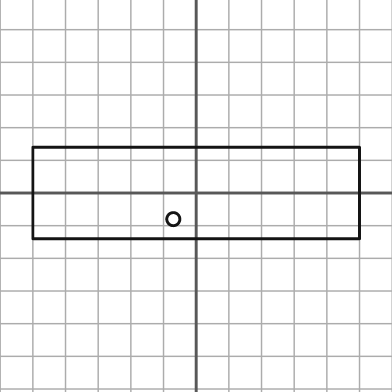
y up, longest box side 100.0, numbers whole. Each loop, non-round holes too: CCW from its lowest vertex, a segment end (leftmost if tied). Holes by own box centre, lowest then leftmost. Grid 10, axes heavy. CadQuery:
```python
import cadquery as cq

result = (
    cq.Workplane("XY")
    .moveTo(-50.0, -14.0)
    .lineTo(50.0, -14.0)
    .lineTo(50.0, 14.0)
    .lineTo(-50.0, 14.0)
    .close()
    .moveTo(-7.0, -8.0)
    .circle(2.0)
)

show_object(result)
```